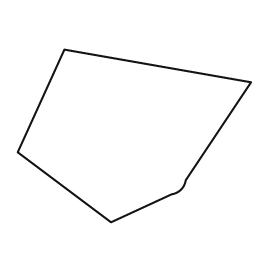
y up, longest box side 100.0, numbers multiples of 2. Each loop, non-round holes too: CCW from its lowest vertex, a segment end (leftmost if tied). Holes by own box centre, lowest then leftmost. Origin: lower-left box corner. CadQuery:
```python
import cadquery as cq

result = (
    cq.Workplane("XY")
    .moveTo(40.0, 0.0)
    .lineTo(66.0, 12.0)
    .threePointArc((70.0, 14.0), (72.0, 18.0))
    .lineTo(100.0, 60.0)
    .lineTo(20.0, 74.0)
    .lineTo(0.0, 30.0)
    .close()
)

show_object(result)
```